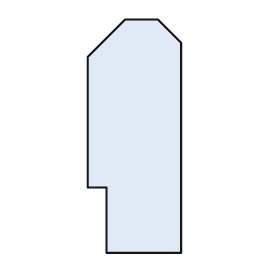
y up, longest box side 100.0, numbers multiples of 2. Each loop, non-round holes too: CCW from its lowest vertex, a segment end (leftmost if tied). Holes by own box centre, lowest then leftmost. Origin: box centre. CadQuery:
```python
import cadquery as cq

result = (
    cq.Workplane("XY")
    .moveTo(-12.0, -50.0)
    .lineTo(20.0, -50.0)
    .lineTo(20.0, 40.0)
    .lineTo(10.0, 50.0)
    .lineTo(-4.0, 50.0)
    .lineTo(-20.0, 34.0)
    .lineTo(-20.0, -22.0)
    .lineTo(-12.0, -22.0)
    .close()
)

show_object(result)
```